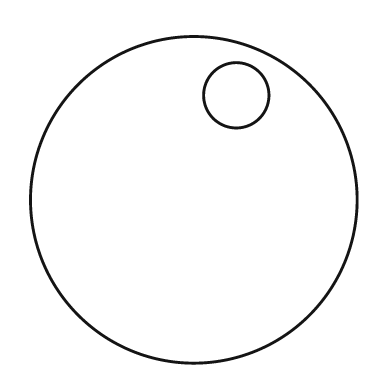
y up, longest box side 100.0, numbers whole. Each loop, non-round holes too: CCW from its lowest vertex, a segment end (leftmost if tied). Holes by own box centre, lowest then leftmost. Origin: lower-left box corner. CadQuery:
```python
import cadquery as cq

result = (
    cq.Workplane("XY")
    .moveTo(50.0, 50.0)
    .circle(50.0)
    .moveTo(63.0, 82.0)
    .circle(10.0)
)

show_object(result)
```